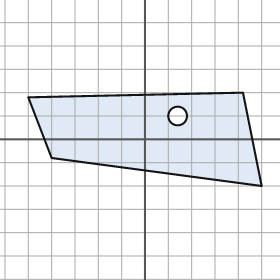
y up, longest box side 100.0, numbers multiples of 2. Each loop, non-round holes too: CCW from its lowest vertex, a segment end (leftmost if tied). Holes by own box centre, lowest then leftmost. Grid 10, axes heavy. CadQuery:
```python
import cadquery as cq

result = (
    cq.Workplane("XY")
    .moveTo(50.0, -20.0)
    .lineTo(42.0, 20.0)
    .lineTo(-50.0, 18.0)
    .lineTo(-40.0, -8.0)
    .close()
    .moveTo(14.0, 10.0)
    .circle(4.0)
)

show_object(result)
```